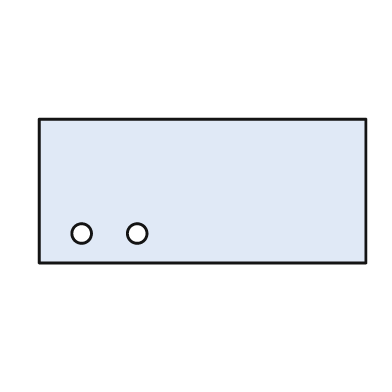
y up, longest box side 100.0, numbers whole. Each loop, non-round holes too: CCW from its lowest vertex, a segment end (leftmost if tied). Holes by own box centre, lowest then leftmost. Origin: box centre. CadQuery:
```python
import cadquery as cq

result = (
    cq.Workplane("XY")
    .moveTo(-50.0, -22.0)
    .lineTo(50.0, -22.0)
    .lineTo(50.0, 22.0)
    .lineTo(-50.0, 22.0)
    .close()
    .moveTo(-37.0, -13.0)
    .circle(3.0)
    .moveTo(-20.0, -13.0)
    .circle(3.0)
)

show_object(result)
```